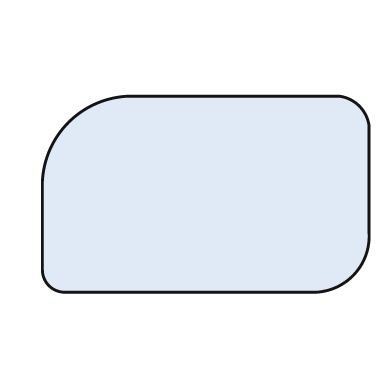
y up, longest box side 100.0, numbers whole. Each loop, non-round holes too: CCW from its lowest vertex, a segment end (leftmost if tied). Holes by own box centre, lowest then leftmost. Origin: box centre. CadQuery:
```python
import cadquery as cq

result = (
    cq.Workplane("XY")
    .moveTo(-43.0, -30.0)
    .lineTo(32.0, -30.0)
    .threePointArc((45.0, -25.0), (50.0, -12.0))
    .lineTo(50.0, 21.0)
    .threePointArc((47.0, 27.0), (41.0, 30.0))
    .lineTo(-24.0, 30.0)
    .threePointArc((-42.0, 22.0), (-50.0, 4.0))
    .lineTo(-50.0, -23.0)
    .threePointArc((-48.0, -28.0), (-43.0, -30.0))
    .close()
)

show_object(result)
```